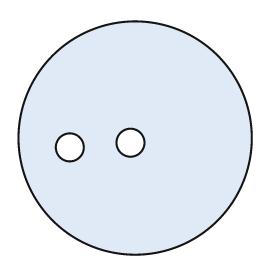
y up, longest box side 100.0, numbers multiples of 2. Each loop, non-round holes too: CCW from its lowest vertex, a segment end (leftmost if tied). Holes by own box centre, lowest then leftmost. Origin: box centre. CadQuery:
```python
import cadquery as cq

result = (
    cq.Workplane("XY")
    .moveTo(0.0, 0.0)
    .circle(50.0)
    .moveTo(-28.0, -4.0)
    .circle(6.0)
    .moveTo(-2.0, -2.0)
    .circle(6.0)
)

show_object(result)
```